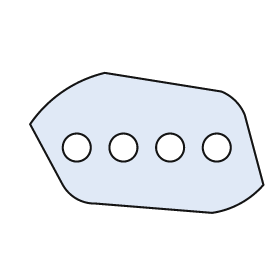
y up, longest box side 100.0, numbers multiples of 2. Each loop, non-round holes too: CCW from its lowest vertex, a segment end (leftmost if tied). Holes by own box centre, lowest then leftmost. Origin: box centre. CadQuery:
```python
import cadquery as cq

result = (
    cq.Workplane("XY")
    .moveTo(28.0, -30.0)
    .threePointArc((40.0, -26.0), (50.0, -18.0))
    .lineTo(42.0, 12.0)
    .threePointArc((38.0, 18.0), (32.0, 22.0))
    .lineTo(-18.0, 30.0)
    .threePointArc((-36.0, 22.0), (-50.0, 8.0))
    .lineTo(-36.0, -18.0)
    .threePointArc((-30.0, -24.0), (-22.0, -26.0))
    .close()
    .moveTo(-30.0, -2.0)
    .circle(6.0)
    .moveTo(-10.0, -2.0)
    .circle(6.0)
    .moveTo(10.0, -2.0)
    .circle(6.0)
    .moveTo(30.0, -2.0)
    .circle(6.0)
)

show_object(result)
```